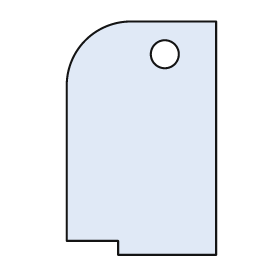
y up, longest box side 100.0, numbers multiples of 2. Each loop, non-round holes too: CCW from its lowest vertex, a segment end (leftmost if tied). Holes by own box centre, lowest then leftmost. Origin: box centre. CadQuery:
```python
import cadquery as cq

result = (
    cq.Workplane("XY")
    .moveTo(-10.0, -50.0)
    .lineTo(32.0, -50.0)
    .lineTo(32.0, 50.0)
    .lineTo(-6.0, 50.0)
    .threePointArc((-24.0, 42.0), (-32.0, 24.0))
    .lineTo(-32.0, -44.0)
    .lineTo(-10.0, -44.0)
    .close()
    .moveTo(10.0, 36.0)
    .circle(6.0)
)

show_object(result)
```